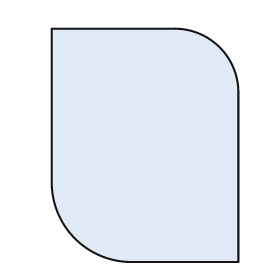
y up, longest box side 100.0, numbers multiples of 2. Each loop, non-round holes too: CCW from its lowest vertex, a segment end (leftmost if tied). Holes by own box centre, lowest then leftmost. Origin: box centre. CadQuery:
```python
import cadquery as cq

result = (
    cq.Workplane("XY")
    .moveTo(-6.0, -50.0)
    .lineTo(40.0, -50.0)
    .lineTo(40.0, 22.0)
    .threePointArc((32.0, 42.0), (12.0, 50.0))
    .lineTo(-40.0, 50.0)
    .lineTo(-40.0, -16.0)
    .threePointArc((-30.0, -40.0), (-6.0, -50.0))
    .close()
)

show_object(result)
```